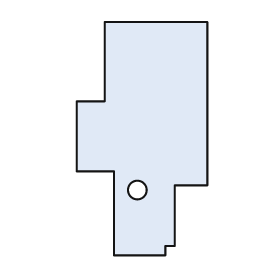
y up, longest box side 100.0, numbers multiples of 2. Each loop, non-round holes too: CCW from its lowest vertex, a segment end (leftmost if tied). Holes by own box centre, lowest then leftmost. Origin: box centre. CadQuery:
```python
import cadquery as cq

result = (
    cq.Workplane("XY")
    .moveTo(-12.0, -50.0)
    .lineTo(10.0, -50.0)
    .lineTo(10.0, -46.0)
    .lineTo(14.0, -46.0)
    .lineTo(14.0, -20.0)
    .lineTo(28.0, -20.0)
    .lineTo(28.0, 50.0)
    .lineTo(-16.0, 50.0)
    .lineTo(-16.0, 16.0)
    .lineTo(-28.0, 16.0)
    .lineTo(-28.0, -14.0)
    .lineTo(-12.0, -14.0)
    .close()
    .moveTo(-2.0, -22.0)
    .circle(4.0)
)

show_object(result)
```